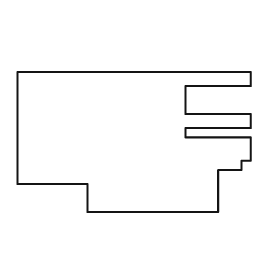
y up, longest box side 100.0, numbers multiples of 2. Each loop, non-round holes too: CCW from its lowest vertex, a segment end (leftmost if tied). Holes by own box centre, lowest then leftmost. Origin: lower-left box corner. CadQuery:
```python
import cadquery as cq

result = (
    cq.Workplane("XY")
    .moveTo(30.0, 0.0)
    .lineTo(86.0, 0.0)
    .lineTo(86.0, 18.0)
    .lineTo(96.0, 18.0)
    .lineTo(96.0, 22.0)
    .lineTo(100.0, 22.0)
    .lineTo(100.0, 32.0)
    .lineTo(72.0, 32.0)
    .lineTo(72.0, 36.0)
    .lineTo(100.0, 36.0)
    .lineTo(100.0, 42.0)
    .lineTo(72.0, 42.0)
    .lineTo(72.0, 54.0)
    .lineTo(100.0, 54.0)
    .lineTo(100.0, 60.0)
    .lineTo(0.0, 60.0)
    .lineTo(0.0, 12.0)
    .lineTo(30.0, 12.0)
    .close()
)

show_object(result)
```